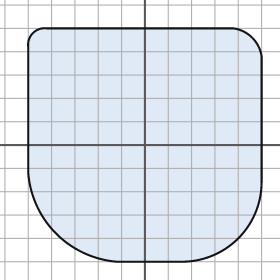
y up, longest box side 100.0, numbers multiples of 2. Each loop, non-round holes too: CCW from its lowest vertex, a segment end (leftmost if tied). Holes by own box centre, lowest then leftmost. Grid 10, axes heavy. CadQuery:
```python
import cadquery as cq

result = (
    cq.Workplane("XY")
    .moveTo(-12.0, -50.0)
    .lineTo(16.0, -50.0)
    .threePointArc((40.0, -40.0), (50.0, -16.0))
    .lineTo(50.0, 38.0)
    .threePointArc((46.0, 46.0), (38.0, 50.0))
    .lineTo(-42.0, 50.0)
    .threePointArc((-48.0, 48.0), (-50.0, 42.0))
    .lineTo(-50.0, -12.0)
    .threePointArc((-38.0, -38.0), (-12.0, -50.0))
    .close()
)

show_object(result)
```